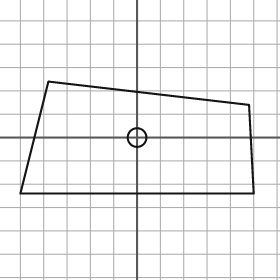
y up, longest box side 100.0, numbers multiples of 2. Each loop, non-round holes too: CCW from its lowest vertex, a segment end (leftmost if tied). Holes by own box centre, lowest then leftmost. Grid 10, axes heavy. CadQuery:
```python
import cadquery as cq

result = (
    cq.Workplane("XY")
    .moveTo(-50.0, -24.0)
    .lineTo(50.0, -24.0)
    .lineTo(48.0, 14.0)
    .lineTo(-38.0, 24.0)
    .close()
    .moveTo(0.0, 0.0)
    .circle(4.0)
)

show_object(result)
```